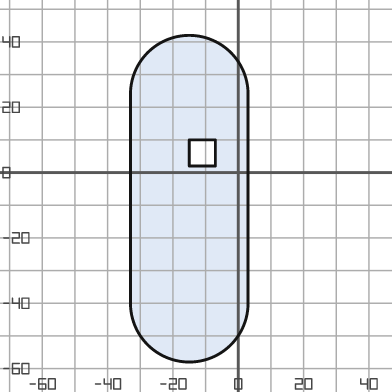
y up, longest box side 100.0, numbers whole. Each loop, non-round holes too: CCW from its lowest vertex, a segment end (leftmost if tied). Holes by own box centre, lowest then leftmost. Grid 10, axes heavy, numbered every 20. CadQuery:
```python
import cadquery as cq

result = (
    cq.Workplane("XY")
    .moveTo(-33.0, -40.0)
    .threePointArc((-15.0, -58.0), (3.0, -40.0))
    .lineTo(3.0, 24.0)
    .threePointArc((-15.0, 42.0), (-33.0, 24.0))
    .close()
    .moveTo(-15.0, 2.0)
    .lineTo(-7.0, 2.0)
    .lineTo(-7.0, 10.0)
    .lineTo(-15.0, 10.0)
    .close()
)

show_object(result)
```